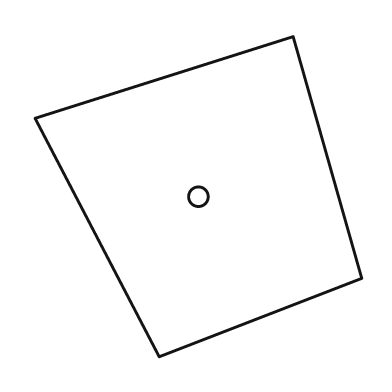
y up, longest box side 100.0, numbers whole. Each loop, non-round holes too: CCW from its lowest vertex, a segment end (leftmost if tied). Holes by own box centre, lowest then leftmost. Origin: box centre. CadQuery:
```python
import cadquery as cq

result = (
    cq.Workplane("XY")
    .moveTo(-12.0, -49.0)
    .lineTo(50.0, -25.0)
    .lineTo(29.0, 49.0)
    .lineTo(-50.0, 24.0)
    .close()
    .moveTo(0.0, 0.0)
    .circle(3.0)
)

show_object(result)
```